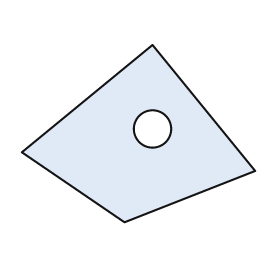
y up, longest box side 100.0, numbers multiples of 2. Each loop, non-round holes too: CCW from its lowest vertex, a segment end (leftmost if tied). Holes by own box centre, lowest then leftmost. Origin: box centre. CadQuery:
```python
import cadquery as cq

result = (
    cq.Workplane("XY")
    .moveTo(-6.0, -38.0)
    .lineTo(50.0, -16.0)
    .lineTo(6.0, 38.0)
    .lineTo(-50.0, -8.0)
    .close()
    .moveTo(6.0, 2.0)
    .circle(8.0)
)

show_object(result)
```